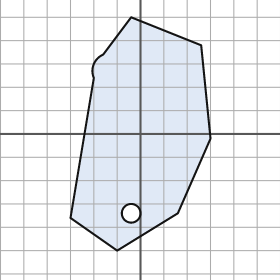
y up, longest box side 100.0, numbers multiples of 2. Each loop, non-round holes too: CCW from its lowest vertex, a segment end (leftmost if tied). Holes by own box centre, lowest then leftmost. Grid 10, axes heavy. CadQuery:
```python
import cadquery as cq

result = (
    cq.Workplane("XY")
    .moveTo(-10.0, -50.0)
    .lineTo(16.0, -34.0)
    .lineTo(30.0, -2.0)
    .lineTo(26.0, 38.0)
    .lineTo(-4.0, 50.0)
    .lineTo(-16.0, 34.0)
    .threePointArc((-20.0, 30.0), (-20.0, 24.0))
    .lineTo(-30.0, -36.0)
    .close()
    .moveTo(-4.0, -34.0)
    .circle(4.0)
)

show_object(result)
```